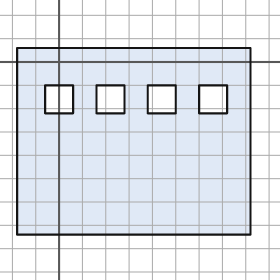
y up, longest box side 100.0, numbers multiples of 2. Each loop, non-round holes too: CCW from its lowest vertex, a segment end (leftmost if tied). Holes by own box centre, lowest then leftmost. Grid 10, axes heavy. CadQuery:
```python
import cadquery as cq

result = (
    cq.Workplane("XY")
    .moveTo(-18.0, -74.0)
    .lineTo(82.0, -74.0)
    .lineTo(82.0, 6.0)
    .lineTo(-18.0, 6.0)
    .close()
    .moveTo(-6.0, -22.0)
    .lineTo(6.0, -22.0)
    .lineTo(6.0, -10.0)
    .lineTo(-6.0, -10.0)
    .close()
    .moveTo(16.0, -22.0)
    .lineTo(28.0, -22.0)
    .lineTo(28.0, -10.0)
    .lineTo(16.0, -10.0)
    .close()
    .moveTo(38.0, -22.0)
    .lineTo(50.0, -22.0)
    .lineTo(50.0, -10.0)
    .lineTo(38.0, -10.0)
    .close()
    .moveTo(60.0, -22.0)
    .lineTo(72.0, -22.0)
    .lineTo(72.0, -10.0)
    .lineTo(60.0, -10.0)
    .close()
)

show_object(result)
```